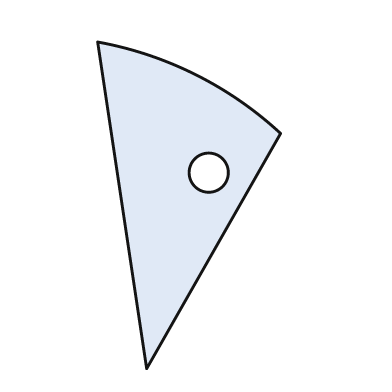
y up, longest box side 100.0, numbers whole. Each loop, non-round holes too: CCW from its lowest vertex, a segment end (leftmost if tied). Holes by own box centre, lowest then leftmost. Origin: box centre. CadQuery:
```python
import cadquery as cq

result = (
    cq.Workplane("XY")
    .moveTo(-13.0, -50.0)
    .lineTo(28.0, 22.0)
    .threePointArc((2.0, 40.0), (-28.0, 50.0))
    .close()
    .moveTo(6.0, 10.0)
    .circle(6.0)
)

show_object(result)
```